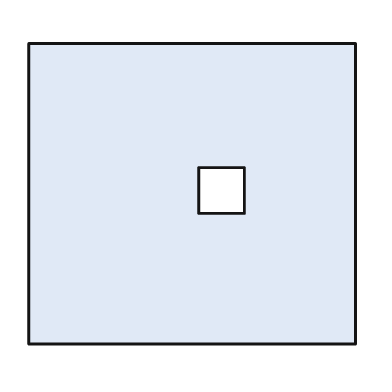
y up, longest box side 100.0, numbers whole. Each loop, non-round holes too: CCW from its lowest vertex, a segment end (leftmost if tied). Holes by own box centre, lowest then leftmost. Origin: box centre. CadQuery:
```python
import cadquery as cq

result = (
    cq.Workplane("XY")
    .moveTo(-50.0, -46.0)
    .lineTo(50.0, -46.0)
    .lineTo(50.0, 46.0)
    .lineTo(-50.0, 46.0)
    .close()
    .moveTo(2.0, -6.0)
    .lineTo(16.0, -6.0)
    .lineTo(16.0, 8.0)
    .lineTo(2.0, 8.0)
    .close()
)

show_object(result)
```